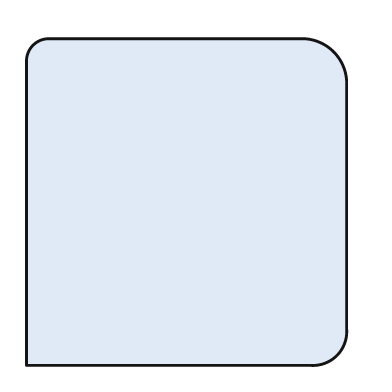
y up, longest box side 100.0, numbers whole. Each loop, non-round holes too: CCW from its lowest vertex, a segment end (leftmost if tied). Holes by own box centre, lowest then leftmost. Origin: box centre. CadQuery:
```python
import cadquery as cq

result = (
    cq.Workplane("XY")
    .moveTo(-49.0, -50.0)
    .lineTo(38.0, -50.0)
    .threePointArc((46.0, -47.0), (49.0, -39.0))
    .lineTo(49.0, 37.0)
    .threePointArc((45.0, 46.0), (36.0, 50.0))
    .lineTo(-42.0, 50.0)
    .threePointArc((-47.0, 48.0), (-49.0, 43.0))
    .close()
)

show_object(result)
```